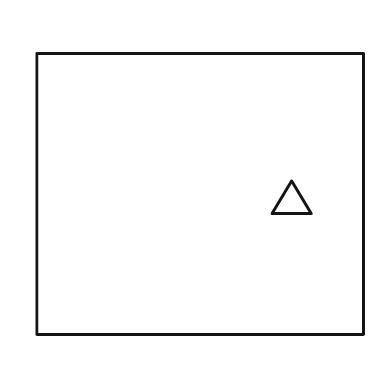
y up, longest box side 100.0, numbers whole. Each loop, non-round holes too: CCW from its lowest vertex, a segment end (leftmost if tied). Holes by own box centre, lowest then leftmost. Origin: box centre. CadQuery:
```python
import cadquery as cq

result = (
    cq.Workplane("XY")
    .moveTo(-50.0, -43.0)
    .lineTo(50.0, -43.0)
    .lineTo(50.0, 43.0)
    .lineTo(-50.0, 43.0)
    .close()
    .moveTo(22.0, -6.0)
    .lineTo(34.0, -6.0)
    .lineTo(28.0, 4.0)
    .close()
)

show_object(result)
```